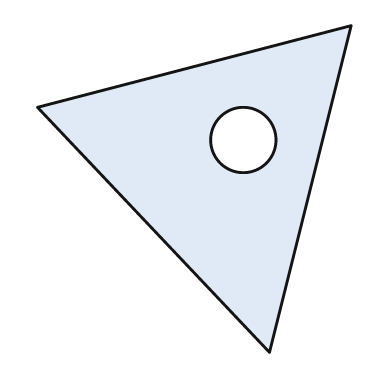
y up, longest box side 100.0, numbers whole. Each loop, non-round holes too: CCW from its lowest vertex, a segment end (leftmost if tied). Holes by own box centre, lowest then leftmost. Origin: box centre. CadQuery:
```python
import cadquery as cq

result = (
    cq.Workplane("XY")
    .moveTo(23.0, -50.0)
    .lineTo(48.0, 50.0)
    .lineTo(-48.0, 25.0)
    .close()
    .moveTo(15.0, 15.0)
    .circle(10.0)
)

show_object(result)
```